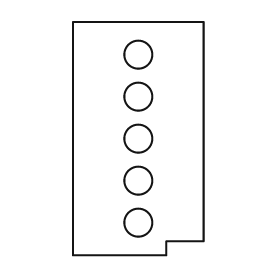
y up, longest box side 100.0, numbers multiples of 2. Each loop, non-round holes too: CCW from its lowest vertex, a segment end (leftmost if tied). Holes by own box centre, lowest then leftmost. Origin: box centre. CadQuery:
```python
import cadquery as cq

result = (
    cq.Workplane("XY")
    .moveTo(-28.0, -50.0)
    .lineTo(12.0, -50.0)
    .lineTo(12.0, -44.0)
    .lineTo(28.0, -44.0)
    .lineTo(28.0, 50.0)
    .lineTo(-28.0, 50.0)
    .close()
    .moveTo(0.0, -36.0)
    .circle(6.0)
    .moveTo(0.0, -18.0)
    .circle(6.0)
    .moveTo(0.0, 0.0)
    .circle(6.0)
    .moveTo(0.0, 18.0)
    .circle(6.0)
    .moveTo(0.0, 36.0)
    .circle(6.0)
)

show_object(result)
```